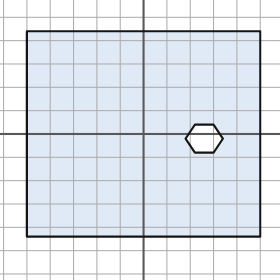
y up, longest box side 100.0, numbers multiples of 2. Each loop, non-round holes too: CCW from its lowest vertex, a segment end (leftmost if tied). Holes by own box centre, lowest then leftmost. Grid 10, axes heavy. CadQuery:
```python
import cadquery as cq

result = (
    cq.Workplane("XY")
    .moveTo(-50.0, -44.0)
    .lineTo(50.0, -44.0)
    .lineTo(50.0, 44.0)
    .lineTo(-50.0, 44.0)
    .close()
    .moveTo(22.0, -8.0)
    .lineTo(30.0, -8.0)
    .lineTo(34.0, -2.0)
    .lineTo(30.0, 4.0)
    .lineTo(22.0, 4.0)
    .lineTo(18.0, -2.0)
    .close()
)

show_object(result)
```